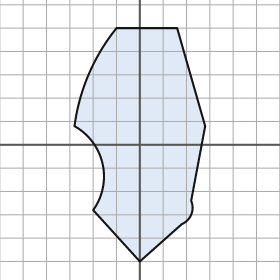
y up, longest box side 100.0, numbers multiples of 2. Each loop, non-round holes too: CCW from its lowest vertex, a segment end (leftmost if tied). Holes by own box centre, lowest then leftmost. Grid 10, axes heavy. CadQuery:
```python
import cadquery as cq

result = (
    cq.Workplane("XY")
    .moveTo(0.0, -50.0)
    .lineTo(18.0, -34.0)
    .threePointArc((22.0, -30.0), (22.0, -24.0))
    .lineTo(28.0, 8.0)
    .lineTo(16.0, 50.0)
    .lineTo(-10.0, 50.0)
    .threePointArc((-22.0, 30.0), (-28.0, 8.0))
    .threePointArc((-16.0, -8.0), (-20.0, -28.0))
    .close()
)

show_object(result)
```